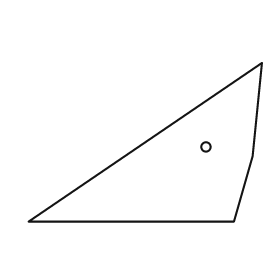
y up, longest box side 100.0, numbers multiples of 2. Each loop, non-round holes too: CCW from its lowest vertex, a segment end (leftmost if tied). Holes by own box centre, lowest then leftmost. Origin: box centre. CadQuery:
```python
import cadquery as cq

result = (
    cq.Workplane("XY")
    .moveTo(-50.0, -34.0)
    .lineTo(38.0, -34.0)
    .lineTo(46.0, -6.0)
    .lineTo(50.0, 34.0)
    .close()
    .moveTo(26.0, -2.0)
    .circle(2.0)
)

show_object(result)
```